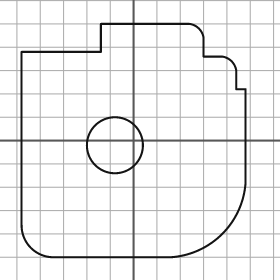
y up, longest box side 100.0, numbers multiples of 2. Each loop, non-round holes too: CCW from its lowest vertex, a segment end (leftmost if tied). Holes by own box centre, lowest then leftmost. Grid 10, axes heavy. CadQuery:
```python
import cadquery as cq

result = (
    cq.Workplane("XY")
    .moveTo(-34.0, -50.0)
    .lineTo(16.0, -50.0)
    .threePointArc((38.0, -40.0), (48.0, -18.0))
    .lineTo(48.0, 22.0)
    .lineTo(44.0, 22.0)
    .lineTo(44.0, 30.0)
    .threePointArc((42.0, 34.0), (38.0, 36.0))
    .lineTo(30.0, 36.0)
    .lineTo(30.0, 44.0)
    .threePointArc((28.0, 48.0), (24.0, 50.0))
    .lineTo(-14.0, 50.0)
    .lineTo(-14.0, 38.0)
    .lineTo(-48.0, 38.0)
    .lineTo(-48.0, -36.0)
    .threePointArc((-44.0, -46.0), (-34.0, -50.0))
    .close()
    .moveTo(-8.0, -2.0)
    .circle(12.0)
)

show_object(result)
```